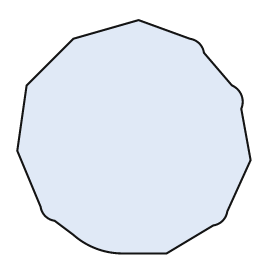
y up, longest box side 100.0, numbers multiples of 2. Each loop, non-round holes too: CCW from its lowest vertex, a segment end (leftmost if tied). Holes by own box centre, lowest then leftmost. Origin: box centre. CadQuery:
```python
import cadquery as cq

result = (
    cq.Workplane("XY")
    .moveTo(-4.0, -50.0)
    .lineTo(14.0, -50.0)
    .lineTo(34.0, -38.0)
    .threePointArc((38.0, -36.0), (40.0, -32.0))
    .lineTo(50.0, -10.0)
    .lineTo(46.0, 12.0)
    .threePointArc((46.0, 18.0), (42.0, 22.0))
    .lineTo(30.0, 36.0)
    .threePointArc((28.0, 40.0), (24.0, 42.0))
    .lineTo(2.0, 50.0)
    .lineTo(-26.0, 42.0)
    .lineTo(-46.0, 22.0)
    .lineTo(-50.0, -6.0)
    .lineTo(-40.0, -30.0)
    .threePointArc((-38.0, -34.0), (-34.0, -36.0))
    .lineTo(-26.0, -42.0)
    .threePointArc((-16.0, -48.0), (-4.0, -50.0))
    .close()
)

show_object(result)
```